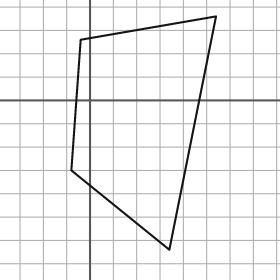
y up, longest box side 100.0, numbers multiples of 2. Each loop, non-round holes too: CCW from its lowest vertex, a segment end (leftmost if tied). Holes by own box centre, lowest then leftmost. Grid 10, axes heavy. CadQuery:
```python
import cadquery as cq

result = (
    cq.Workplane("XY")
    .moveTo(34.0, -64.0)
    .lineTo(54.0, 36.0)
    .lineTo(-4.0, 26.0)
    .lineTo(-8.0, -30.0)
    .close()
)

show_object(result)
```